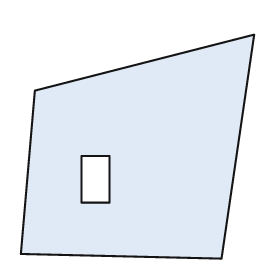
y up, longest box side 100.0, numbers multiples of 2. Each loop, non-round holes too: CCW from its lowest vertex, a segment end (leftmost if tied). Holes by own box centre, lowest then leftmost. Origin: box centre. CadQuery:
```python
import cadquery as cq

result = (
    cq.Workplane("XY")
    .moveTo(36.0, -48.0)
    .lineTo(50.0, 48.0)
    .lineTo(-44.0, 24.0)
    .lineTo(-50.0, -46.0)
    .close()
    .moveTo(-24.0, -24.0)
    .lineTo(-12.0, -24.0)
    .lineTo(-12.0, -4.0)
    .lineTo(-24.0, -4.0)
    .close()
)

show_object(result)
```